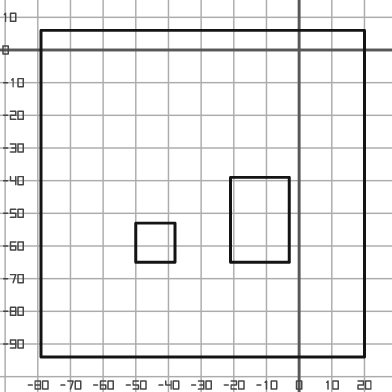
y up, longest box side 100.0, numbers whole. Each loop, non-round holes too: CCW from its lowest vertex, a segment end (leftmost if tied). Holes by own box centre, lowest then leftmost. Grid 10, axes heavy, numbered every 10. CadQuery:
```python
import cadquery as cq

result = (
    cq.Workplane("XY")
    .moveTo(-79.0, -94.0)
    .lineTo(20.0, -94.0)
    .lineTo(20.0, 6.0)
    .lineTo(-79.0, 6.0)
    .close()
    .moveTo(-50.0, -65.0)
    .lineTo(-38.0, -65.0)
    .lineTo(-38.0, -53.0)
    .lineTo(-50.0, -53.0)
    .close()
    .moveTo(-21.0, -65.0)
    .lineTo(-3.0, -65.0)
    .lineTo(-3.0, -39.0)
    .lineTo(-21.0, -39.0)
    .close()
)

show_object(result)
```